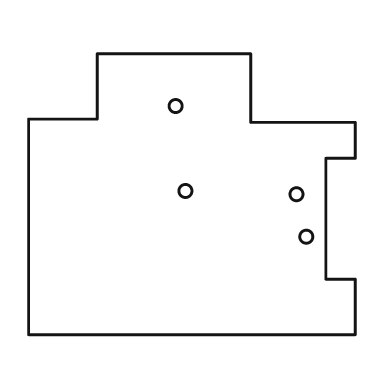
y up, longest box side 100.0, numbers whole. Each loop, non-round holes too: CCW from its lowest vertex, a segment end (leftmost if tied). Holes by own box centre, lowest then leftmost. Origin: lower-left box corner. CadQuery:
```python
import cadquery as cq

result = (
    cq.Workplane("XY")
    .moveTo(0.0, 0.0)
    .lineTo(100.0, 0.0)
    .lineTo(100.0, 17.0)
    .lineTo(91.0, 17.0)
    .lineTo(91.0, 54.0)
    .lineTo(100.0, 54.0)
    .lineTo(100.0, 65.0)
    .lineTo(68.0, 65.0)
    .lineTo(68.0, 86.0)
    .lineTo(21.0, 86.0)
    .lineTo(21.0, 66.0)
    .lineTo(0.0, 66.0)
    .close()
    .moveTo(85.0, 30.0)
    .circle(2.0)
    .moveTo(82.0, 43.0)
    .circle(2.0)
    .moveTo(48.0, 44.0)
    .circle(2.0)
    .moveTo(45.0, 70.0)
    .circle(2.0)
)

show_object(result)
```